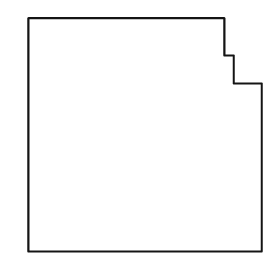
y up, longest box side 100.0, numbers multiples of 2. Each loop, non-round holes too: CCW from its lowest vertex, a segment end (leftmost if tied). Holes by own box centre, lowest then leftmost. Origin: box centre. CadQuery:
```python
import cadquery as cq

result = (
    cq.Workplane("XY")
    .moveTo(-50.0, -50.0)
    .lineTo(50.0, -50.0)
    .lineTo(50.0, 22.0)
    .lineTo(38.0, 22.0)
    .lineTo(38.0, 34.0)
    .lineTo(34.0, 34.0)
    .lineTo(34.0, 50.0)
    .lineTo(-50.0, 50.0)
    .close()
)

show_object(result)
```